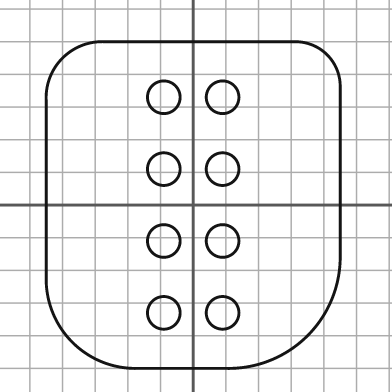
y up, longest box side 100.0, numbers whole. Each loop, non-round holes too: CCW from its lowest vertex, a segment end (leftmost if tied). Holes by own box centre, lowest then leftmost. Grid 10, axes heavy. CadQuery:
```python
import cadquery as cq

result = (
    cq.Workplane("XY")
    .moveTo(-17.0, -50.0)
    .lineTo(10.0, -50.0)
    .threePointArc((35.0, -40.0), (45.0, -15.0))
    .lineTo(45.0, 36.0)
    .threePointArc((41.0, 46.0), (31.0, 50.0))
    .lineTo(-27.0, 50.0)
    .threePointArc((-40.0, 45.0), (-45.0, 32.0))
    .lineTo(-45.0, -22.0)
    .threePointArc((-37.0, -42.0), (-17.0, -50.0))
    .close()
    .moveTo(-9.0, -33.0)
    .circle(5.0)
    .moveTo(9.0, -33.0)
    .circle(5.0)
    .moveTo(-9.0, -11.0)
    .circle(5.0)
    .moveTo(9.0, -11.0)
    .circle(5.0)
    .moveTo(-9.0, 11.0)
    .circle(5.0)
    .moveTo(9.0, 11.0)
    .circle(5.0)
    .moveTo(-9.0, 33.0)
    .circle(5.0)
    .moveTo(9.0, 33.0)
    .circle(5.0)
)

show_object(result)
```